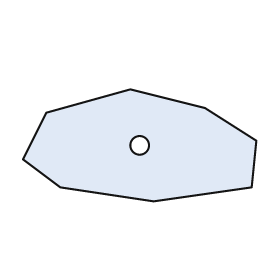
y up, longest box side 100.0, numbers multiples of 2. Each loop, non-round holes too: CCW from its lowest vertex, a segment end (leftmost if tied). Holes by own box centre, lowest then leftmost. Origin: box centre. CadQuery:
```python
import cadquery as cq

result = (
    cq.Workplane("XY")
    .moveTo(6.0, -24.0)
    .lineTo(48.0, -18.0)
    .lineTo(50.0, 2.0)
    .lineTo(28.0, 16.0)
    .lineTo(-4.0, 24.0)
    .lineTo(-40.0, 14.0)
    .lineTo(-50.0, -6.0)
    .lineTo(-34.0, -18.0)
    .close()
    .moveTo(0.0, 0.0)
    .circle(4.0)
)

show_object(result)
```